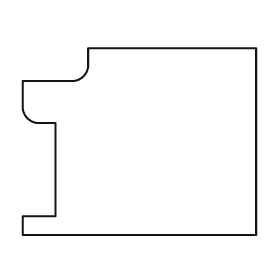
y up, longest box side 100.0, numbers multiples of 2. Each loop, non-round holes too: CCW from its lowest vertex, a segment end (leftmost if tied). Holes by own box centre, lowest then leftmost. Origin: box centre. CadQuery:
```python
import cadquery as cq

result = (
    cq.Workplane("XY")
    .moveTo(-50.0, -40.0)
    .lineTo(50.0, -40.0)
    .lineTo(50.0, 40.0)
    .lineTo(-22.0, 40.0)
    .lineTo(-22.0, 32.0)
    .threePointArc((-24.0, 28.0), (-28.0, 26.0))
    .lineTo(-50.0, 26.0)
    .lineTo(-50.0, 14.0)
    .threePointArc((-48.0, 10.0), (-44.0, 8.0))
    .lineTo(-36.0, 8.0)
    .lineTo(-36.0, -32.0)
    .lineTo(-50.0, -32.0)
    .close()
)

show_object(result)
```